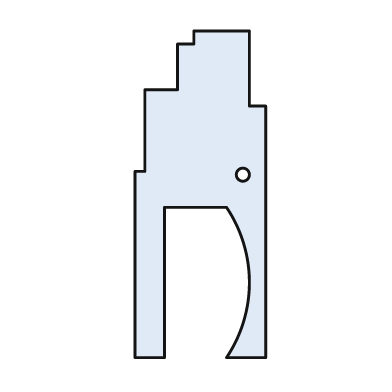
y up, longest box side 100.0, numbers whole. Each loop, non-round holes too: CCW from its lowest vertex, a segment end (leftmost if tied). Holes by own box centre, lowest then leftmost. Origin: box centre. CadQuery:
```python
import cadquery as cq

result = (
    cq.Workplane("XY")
    .moveTo(-20.0, -50.0)
    .lineTo(-11.0, -50.0)
    .lineTo(-11.0, -4.0)
    .lineTo(8.0, -4.0)
    .threePointArc((15.0, -27.0), (8.0, -50.0))
    .lineTo(20.0, -50.0)
    .lineTo(20.0, 27.0)
    .lineTo(15.0, 27.0)
    .lineTo(15.0, 50.0)
    .lineTo(-2.0, 50.0)
    .lineTo(-2.0, 46.0)
    .lineTo(-7.0, 46.0)
    .lineTo(-7.0, 32.0)
    .lineTo(-17.0, 32.0)
    .lineTo(-17.0, 7.0)
    .lineTo(-20.0, 7.0)
    .close()
    .moveTo(13.0, 6.0)
    .circle(2.0)
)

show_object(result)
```